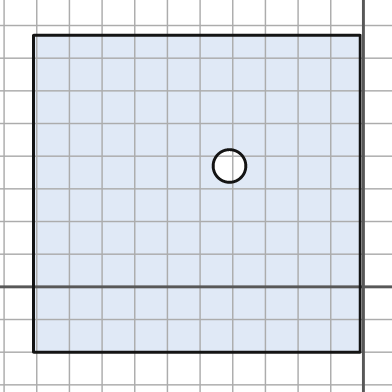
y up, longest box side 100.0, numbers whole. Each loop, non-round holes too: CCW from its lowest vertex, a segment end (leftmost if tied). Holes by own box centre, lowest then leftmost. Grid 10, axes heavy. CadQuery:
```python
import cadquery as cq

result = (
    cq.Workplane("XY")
    .moveTo(-101.0, -20.0)
    .lineTo(-1.0, -20.0)
    .lineTo(-1.0, 77.0)
    .lineTo(-101.0, 77.0)
    .close()
    .moveTo(-41.0, 37.0)
    .circle(5.0)
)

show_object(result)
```